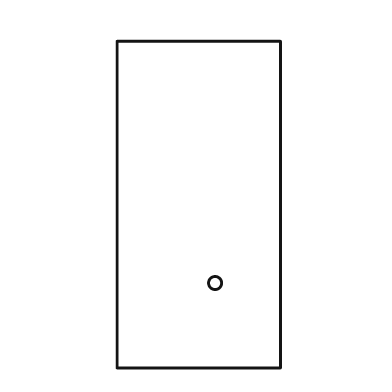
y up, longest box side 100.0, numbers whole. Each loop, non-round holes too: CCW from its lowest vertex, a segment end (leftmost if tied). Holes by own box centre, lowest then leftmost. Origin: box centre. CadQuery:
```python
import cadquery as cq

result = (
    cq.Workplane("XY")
    .moveTo(-25.0, -50.0)
    .lineTo(25.0, -50.0)
    .lineTo(25.0, 50.0)
    .lineTo(-25.0, 50.0)
    .close()
    .moveTo(5.0, -24.0)
    .circle(2.0)
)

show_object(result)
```